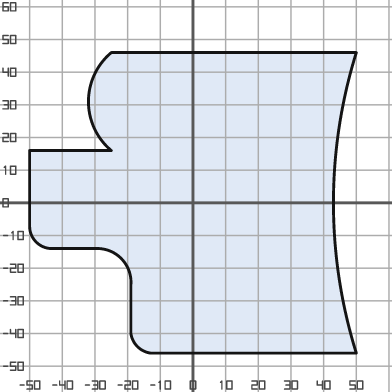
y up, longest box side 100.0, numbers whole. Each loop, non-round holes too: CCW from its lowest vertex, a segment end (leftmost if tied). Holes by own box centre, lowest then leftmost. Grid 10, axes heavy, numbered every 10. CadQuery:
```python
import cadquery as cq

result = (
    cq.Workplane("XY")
    .moveTo(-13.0, -46.0)
    .lineTo(50.0, -46.0)
    .threePointArc((43.0, 0.0), (50.0, 46.0))
    .lineTo(-25.0, 46.0)
    .threePointArc((-32.0, 31.0), (-25.0, 16.0))
    .lineTo(-50.0, 16.0)
    .lineTo(-50.0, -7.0)
    .threePointArc((-48.0, -12.0), (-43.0, -14.0))
    .lineTo(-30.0, -14.0)
    .threePointArc((-22.0, -17.0), (-19.0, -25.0))
    .lineTo(-19.0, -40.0)
    .threePointArc((-17.0, -44.0), (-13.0, -46.0))
    .close()
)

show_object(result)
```